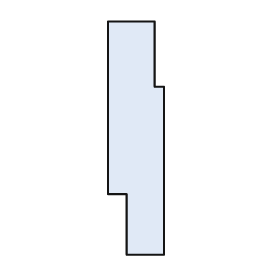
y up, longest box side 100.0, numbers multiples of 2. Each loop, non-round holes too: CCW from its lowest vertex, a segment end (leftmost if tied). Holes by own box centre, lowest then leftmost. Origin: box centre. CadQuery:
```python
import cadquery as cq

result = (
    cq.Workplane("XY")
    .moveTo(-4.0, -50.0)
    .lineTo(12.0, -50.0)
    .lineTo(12.0, 22.0)
    .lineTo(8.0, 22.0)
    .lineTo(8.0, 50.0)
    .lineTo(-12.0, 50.0)
    .lineTo(-12.0, -24.0)
    .lineTo(-4.0, -24.0)
    .close()
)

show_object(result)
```